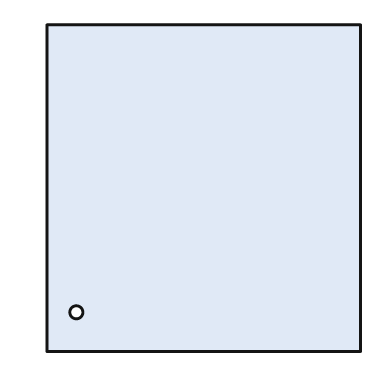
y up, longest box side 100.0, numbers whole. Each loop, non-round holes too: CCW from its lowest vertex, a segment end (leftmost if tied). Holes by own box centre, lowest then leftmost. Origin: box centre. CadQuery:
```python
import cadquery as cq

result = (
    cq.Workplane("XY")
    .moveTo(-48.0, -50.0)
    .lineTo(48.0, -50.0)
    .lineTo(48.0, 50.0)
    .lineTo(-48.0, 50.0)
    .close()
    .moveTo(-39.0, -38.0)
    .circle(2.0)
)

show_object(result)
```